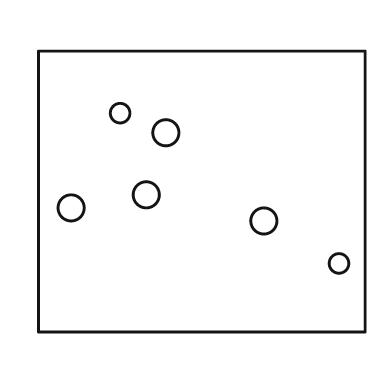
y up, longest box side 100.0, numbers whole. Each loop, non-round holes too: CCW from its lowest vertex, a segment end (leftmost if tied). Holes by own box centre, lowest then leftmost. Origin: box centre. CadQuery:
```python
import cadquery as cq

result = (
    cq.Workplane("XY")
    .moveTo(-50.0, -43.0)
    .lineTo(50.0, -43.0)
    .lineTo(50.0, 43.0)
    .lineTo(-50.0, 43.0)
    .close()
    .moveTo(42.0, -22.0)
    .circle(3.0)
    .moveTo(19.0, -9.0)
    .circle(4.0)
    .moveTo(-40.0, -5.0)
    .circle(4.0)
    .moveTo(-17.0, -1.0)
    .circle(4.0)
    .moveTo(-11.0, 18.0)
    .circle(4.0)
    .moveTo(-25.0, 24.0)
    .circle(3.0)
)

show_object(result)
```